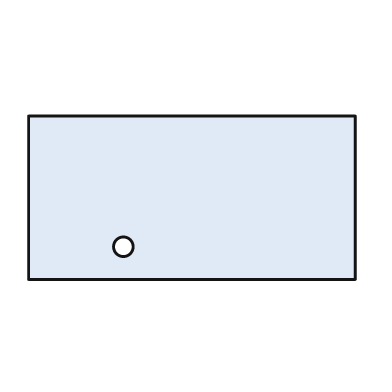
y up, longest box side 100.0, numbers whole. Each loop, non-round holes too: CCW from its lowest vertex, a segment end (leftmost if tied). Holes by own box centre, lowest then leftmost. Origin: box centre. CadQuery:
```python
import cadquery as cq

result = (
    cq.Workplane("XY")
    .moveTo(-50.0, -25.0)
    .lineTo(50.0, -25.0)
    .lineTo(50.0, 25.0)
    .lineTo(-50.0, 25.0)
    .close()
    .moveTo(-21.0, -15.0)
    .circle(3.0)
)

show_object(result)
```